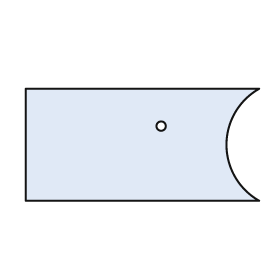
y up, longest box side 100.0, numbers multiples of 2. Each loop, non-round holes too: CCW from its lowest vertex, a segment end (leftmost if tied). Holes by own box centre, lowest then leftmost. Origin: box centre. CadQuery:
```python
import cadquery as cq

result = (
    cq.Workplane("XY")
    .moveTo(-50.0, -24.0)
    .lineTo(50.0, -24.0)
    .threePointArc((36.0, 0.0), (50.0, 24.0))
    .lineTo(-50.0, 24.0)
    .close()
    .moveTo(8.0, 8.0)
    .circle(2.0)
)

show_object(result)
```